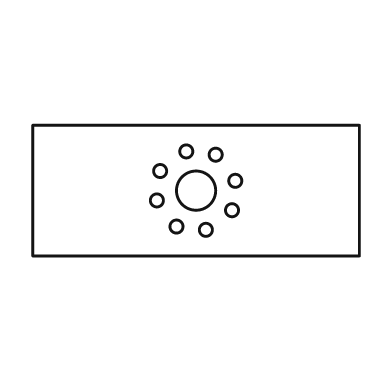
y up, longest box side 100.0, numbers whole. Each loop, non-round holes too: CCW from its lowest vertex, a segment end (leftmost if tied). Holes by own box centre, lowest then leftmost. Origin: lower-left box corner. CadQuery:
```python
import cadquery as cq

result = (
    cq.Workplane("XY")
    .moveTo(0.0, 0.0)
    .lineTo(100.0, 0.0)
    .lineTo(100.0, 40.0)
    .lineTo(0.0, 40.0)
    .close()
    .moveTo(53.0, 8.0)
    .circle(2.0)
    .moveTo(44.0, 9.0)
    .circle(2.0)
    .moveTo(61.0, 14.0)
    .circle(2.0)
    .moveTo(38.0, 17.0)
    .circle(2.0)
    .moveTo(50.0, 20.0)
    .circle(6.0)
    .moveTo(62.0, 23.0)
    .circle(2.0)
    .moveTo(39.0, 26.0)
    .circle(2.0)
    .moveTo(56.0, 31.0)
    .circle(2.0)
    .moveTo(47.0, 32.0)
    .circle(2.0)
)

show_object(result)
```